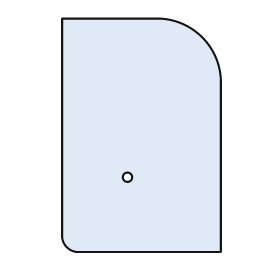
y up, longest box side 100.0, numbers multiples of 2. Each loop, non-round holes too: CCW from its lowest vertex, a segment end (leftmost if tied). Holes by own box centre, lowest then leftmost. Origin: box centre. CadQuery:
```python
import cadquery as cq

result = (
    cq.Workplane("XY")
    .moveTo(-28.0, -50.0)
    .lineTo(34.0, -50.0)
    .lineTo(34.0, 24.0)
    .threePointArc((26.0, 42.0), (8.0, 50.0))
    .lineTo(-34.0, 50.0)
    .lineTo(-34.0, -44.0)
    .threePointArc((-32.0, -48.0), (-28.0, -50.0))
    .close()
    .moveTo(-6.0, -18.0)
    .circle(2.0)
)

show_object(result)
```